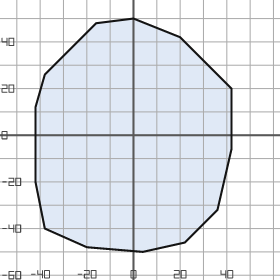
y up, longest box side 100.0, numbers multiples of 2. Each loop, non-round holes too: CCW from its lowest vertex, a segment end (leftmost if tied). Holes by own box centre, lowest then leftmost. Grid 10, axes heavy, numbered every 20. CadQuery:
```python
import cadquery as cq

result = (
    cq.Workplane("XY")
    .moveTo(4.0, -50.0)
    .lineTo(22.0, -46.0)
    .lineTo(36.0, -32.0)
    .lineTo(42.0, -6.0)
    .lineTo(42.0, 20.0)
    .lineTo(20.0, 42.0)
    .lineTo(0.0, 50.0)
    .lineTo(-16.0, 48.0)
    .lineTo(-38.0, 26.0)
    .lineTo(-42.0, 12.0)
    .lineTo(-42.0, -20.0)
    .lineTo(-38.0, -40.0)
    .lineTo(-20.0, -48.0)
    .close()
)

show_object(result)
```